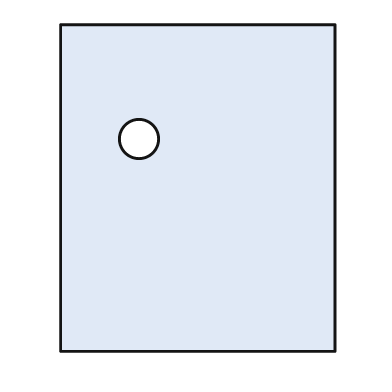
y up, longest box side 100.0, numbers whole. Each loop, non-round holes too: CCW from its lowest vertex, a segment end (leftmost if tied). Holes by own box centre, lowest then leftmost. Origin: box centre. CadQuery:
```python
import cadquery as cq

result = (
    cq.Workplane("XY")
    .moveTo(-42.0, -50.0)
    .lineTo(42.0, -50.0)
    .lineTo(42.0, 50.0)
    .lineTo(-42.0, 50.0)
    .close()
    .moveTo(-18.0, 15.0)
    .circle(6.0)
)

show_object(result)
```